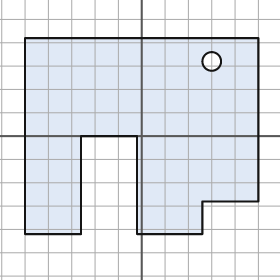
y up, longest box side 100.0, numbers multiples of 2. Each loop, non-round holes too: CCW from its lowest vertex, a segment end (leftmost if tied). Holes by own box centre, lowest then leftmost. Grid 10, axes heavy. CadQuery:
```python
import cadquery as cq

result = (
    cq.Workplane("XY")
    .moveTo(-50.0, -42.0)
    .lineTo(-26.0, -42.0)
    .lineTo(-26.0, 0.0)
    .lineTo(-2.0, 0.0)
    .lineTo(-2.0, -42.0)
    .lineTo(26.0, -42.0)
    .lineTo(26.0, -28.0)
    .lineTo(50.0, -28.0)
    .lineTo(50.0, 42.0)
    .lineTo(-50.0, 42.0)
    .close()
    .moveTo(30.0, 32.0)
    .circle(4.0)
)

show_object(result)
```